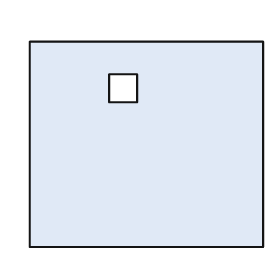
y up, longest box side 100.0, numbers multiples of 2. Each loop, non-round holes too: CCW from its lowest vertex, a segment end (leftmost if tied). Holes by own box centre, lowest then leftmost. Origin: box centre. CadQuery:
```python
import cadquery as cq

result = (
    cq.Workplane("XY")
    .moveTo(-50.0, -44.0)
    .lineTo(50.0, -44.0)
    .lineTo(50.0, 44.0)
    .lineTo(-50.0, 44.0)
    .close()
    .moveTo(-16.0, 18.0)
    .lineTo(-4.0, 18.0)
    .lineTo(-4.0, 30.0)
    .lineTo(-16.0, 30.0)
    .close()
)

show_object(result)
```